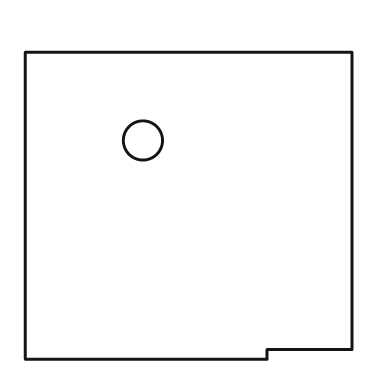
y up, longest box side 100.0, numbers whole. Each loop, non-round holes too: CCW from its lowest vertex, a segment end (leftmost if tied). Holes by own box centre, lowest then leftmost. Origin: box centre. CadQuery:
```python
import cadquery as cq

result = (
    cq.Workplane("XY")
    .moveTo(-50.0, -47.0)
    .lineTo(24.0, -47.0)
    .lineTo(24.0, -44.0)
    .lineTo(50.0, -44.0)
    .lineTo(50.0, 47.0)
    .lineTo(-50.0, 47.0)
    .close()
    .moveTo(-14.0, 20.0)
    .circle(6.0)
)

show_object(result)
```